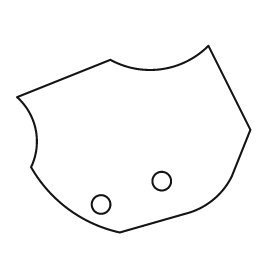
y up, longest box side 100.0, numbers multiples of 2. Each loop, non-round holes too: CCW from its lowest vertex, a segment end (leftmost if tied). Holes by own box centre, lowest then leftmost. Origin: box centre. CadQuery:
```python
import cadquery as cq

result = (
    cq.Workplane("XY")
    .moveTo(-6.0, -40.0)
    .lineTo(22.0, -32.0)
    .threePointArc((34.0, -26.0), (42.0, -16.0))
    .lineTo(50.0, 4.0)
    .lineTo(32.0, 40.0)
    .threePointArc((12.0, 30.0), (-10.0, 34.0))
    .lineTo(-50.0, 18.0)
    .threePointArc((-42.0, 4.0), (-44.0, -12.0))
    .threePointArc((-28.0, -30.0), (-6.0, -40.0))
    .close()
    .moveTo(-14.0, -28.0)
    .circle(4.0)
    .moveTo(12.0, -18.0)
    .circle(4.0)
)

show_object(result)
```